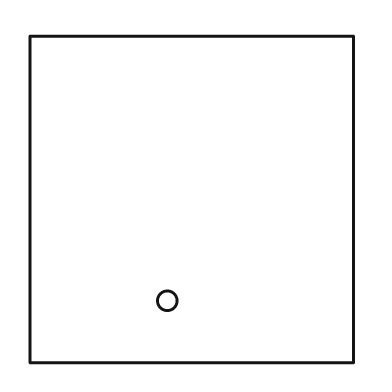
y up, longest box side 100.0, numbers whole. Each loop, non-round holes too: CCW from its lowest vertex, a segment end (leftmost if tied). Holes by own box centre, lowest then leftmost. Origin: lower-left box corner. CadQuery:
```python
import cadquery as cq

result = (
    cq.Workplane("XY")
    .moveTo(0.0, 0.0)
    .lineTo(99.0, 0.0)
    .lineTo(99.0, 100.0)
    .lineTo(0.0, 100.0)
    .close()
    .moveTo(42.0, 19.0)
    .circle(3.0)
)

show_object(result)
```